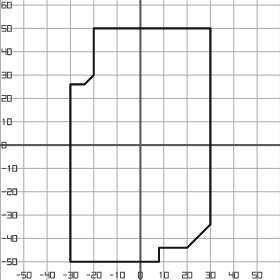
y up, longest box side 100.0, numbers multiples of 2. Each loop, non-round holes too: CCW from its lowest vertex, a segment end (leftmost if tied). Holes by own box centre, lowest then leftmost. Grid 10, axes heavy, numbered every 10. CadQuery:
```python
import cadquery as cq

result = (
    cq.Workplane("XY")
    .moveTo(-30.0, -50.0)
    .lineTo(8.0, -50.0)
    .lineTo(8.0, -44.0)
    .lineTo(20.0, -44.0)
    .lineTo(30.0, -34.0)
    .lineTo(30.0, 50.0)
    .lineTo(-20.0, 50.0)
    .lineTo(-20.0, 30.0)
    .lineTo(-24.0, 26.0)
    .lineTo(-30.0, 26.0)
    .close()
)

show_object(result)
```